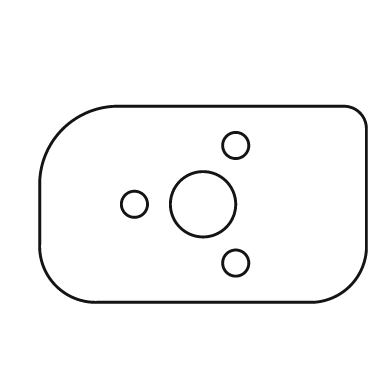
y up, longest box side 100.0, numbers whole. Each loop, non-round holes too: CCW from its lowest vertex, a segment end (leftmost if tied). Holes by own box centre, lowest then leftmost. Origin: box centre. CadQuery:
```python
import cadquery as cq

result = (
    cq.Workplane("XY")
    .moveTo(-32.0, -30.0)
    .lineTo(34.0, -30.0)
    .threePointArc((45.0, -25.0), (50.0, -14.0))
    .lineTo(50.0, 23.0)
    .threePointArc((48.0, 28.0), (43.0, 30.0))
    .lineTo(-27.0, 30.0)
    .threePointArc((-43.0, 23.0), (-50.0, 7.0))
    .lineTo(-50.0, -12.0)
    .threePointArc((-45.0, -25.0), (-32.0, -30.0))
    .close()
    .moveTo(10.0, -18.0)
    .circle(4.0)
    .moveTo(-21.0, 0.0)
    .circle(4.0)
    .moveTo(0.0, 0.0)
    .circle(10.0)
    .moveTo(10.0, 18.0)
    .circle(4.0)
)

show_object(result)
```